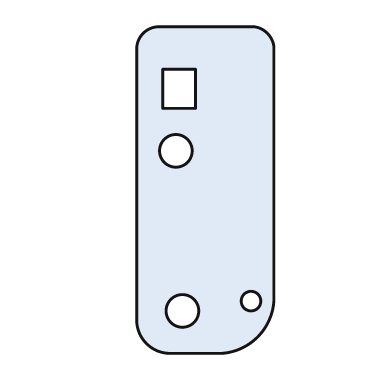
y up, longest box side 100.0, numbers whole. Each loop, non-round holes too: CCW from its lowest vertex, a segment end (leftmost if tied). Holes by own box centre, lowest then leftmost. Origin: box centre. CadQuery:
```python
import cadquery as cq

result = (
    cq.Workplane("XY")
    .moveTo(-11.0, -50.0)
    .lineTo(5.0, -50.0)
    .threePointArc((16.0, -45.0), (21.0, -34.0))
    .lineTo(21.0, 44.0)
    .threePointArc((19.0, 48.0), (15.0, 50.0))
    .lineTo(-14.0, 50.0)
    .threePointArc((-19.0, 48.0), (-21.0, 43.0))
    .lineTo(-21.0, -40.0)
    .threePointArc((-18.0, -47.0), (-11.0, -50.0))
    .close()
    .moveTo(-7.0, -37.0)
    .circle(5.0)
    .moveTo(14.0, -34.0)
    .circle(3.0)
    .moveTo(-9.0, 12.0)
    .circle(5.0)
    .moveTo(-13.0, 25.0)
    .lineTo(-3.0, 25.0)
    .lineTo(-3.0, 37.0)
    .lineTo(-13.0, 37.0)
    .close()
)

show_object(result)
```